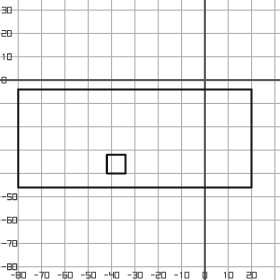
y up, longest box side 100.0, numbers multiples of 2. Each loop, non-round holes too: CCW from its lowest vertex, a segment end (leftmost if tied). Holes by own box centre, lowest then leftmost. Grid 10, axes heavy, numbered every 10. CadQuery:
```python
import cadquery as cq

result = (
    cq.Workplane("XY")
    .moveTo(-80.0, -46.0)
    .lineTo(20.0, -46.0)
    .lineTo(20.0, -4.0)
    .lineTo(-80.0, -4.0)
    .close()
    .moveTo(-42.0, -40.0)
    .lineTo(-34.0, -40.0)
    .lineTo(-34.0, -32.0)
    .lineTo(-42.0, -32.0)
    .close()
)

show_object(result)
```